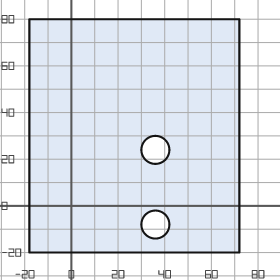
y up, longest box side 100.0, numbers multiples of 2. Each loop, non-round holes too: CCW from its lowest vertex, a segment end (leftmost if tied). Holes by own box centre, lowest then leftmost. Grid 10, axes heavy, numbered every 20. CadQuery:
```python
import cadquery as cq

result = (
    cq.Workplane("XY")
    .moveTo(-18.0, -20.0)
    .lineTo(72.0, -20.0)
    .lineTo(72.0, 80.0)
    .lineTo(-18.0, 80.0)
    .close()
    .moveTo(36.0, -8.0)
    .circle(6.0)
    .moveTo(36.0, 24.0)
    .circle(6.0)
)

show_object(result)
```